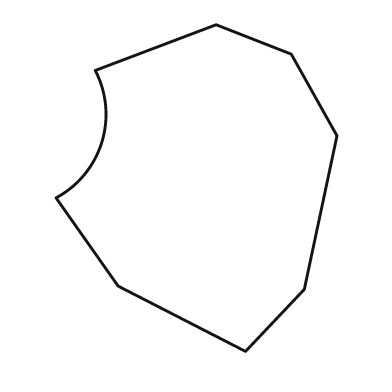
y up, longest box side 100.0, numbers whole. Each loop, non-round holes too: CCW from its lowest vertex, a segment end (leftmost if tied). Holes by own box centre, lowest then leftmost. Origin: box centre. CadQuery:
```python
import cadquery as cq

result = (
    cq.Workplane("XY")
    .moveTo(15.0, -50.0)
    .lineTo(33.0, -31.0)
    .lineTo(43.0, 16.0)
    .lineTo(29.0, 41.0)
    .lineTo(6.0, 50.0)
    .lineTo(-31.0, 36.0)
    .threePointArc((-29.0, 14.0), (-43.0, -3.0))
    .lineTo(-24.0, -30.0)
    .close()
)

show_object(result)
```